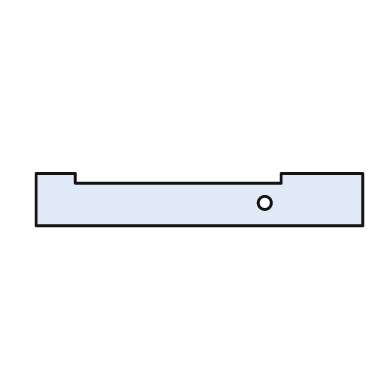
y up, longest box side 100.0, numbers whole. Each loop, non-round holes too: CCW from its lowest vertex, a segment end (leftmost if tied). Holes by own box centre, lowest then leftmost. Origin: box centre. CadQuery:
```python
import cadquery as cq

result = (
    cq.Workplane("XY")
    .moveTo(-50.0, -8.0)
    .lineTo(50.0, -8.0)
    .lineTo(50.0, 8.0)
    .lineTo(25.0, 8.0)
    .lineTo(25.0, 5.0)
    .lineTo(-38.0, 5.0)
    .lineTo(-38.0, 8.0)
    .lineTo(-50.0, 8.0)
    .close()
    .moveTo(20.0, -1.0)
    .circle(2.0)
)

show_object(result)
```